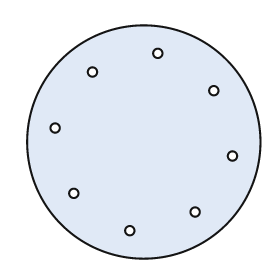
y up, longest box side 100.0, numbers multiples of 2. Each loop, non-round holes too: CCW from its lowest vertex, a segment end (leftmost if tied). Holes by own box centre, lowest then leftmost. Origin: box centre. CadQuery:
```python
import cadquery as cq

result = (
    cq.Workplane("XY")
    .moveTo(0.0, 0.0)
    .circle(50.0)
    .moveTo(-6.0, -38.0)
    .circle(2.0)
    .moveTo(22.0, -30.0)
    .circle(2.0)
    .moveTo(-30.0, -22.0)
    .circle(2.0)
    .moveTo(38.0, -6.0)
    .circle(2.0)
    .moveTo(-38.0, 6.0)
    .circle(2.0)
    .moveTo(30.0, 22.0)
    .circle(2.0)
    .moveTo(-22.0, 30.0)
    .circle(2.0)
    .moveTo(6.0, 38.0)
    .circle(2.0)
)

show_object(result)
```